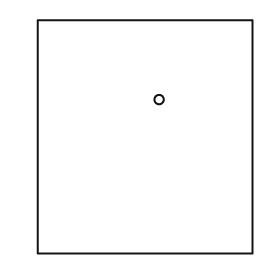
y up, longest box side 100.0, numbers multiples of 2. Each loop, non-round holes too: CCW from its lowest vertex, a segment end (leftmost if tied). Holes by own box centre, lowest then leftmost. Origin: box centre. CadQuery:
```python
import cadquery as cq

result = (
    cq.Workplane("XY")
    .moveTo(-46.0, -50.0)
    .lineTo(46.0, -50.0)
    .lineTo(46.0, 50.0)
    .lineTo(-46.0, 50.0)
    .close()
    .moveTo(6.0, 16.0)
    .circle(2.0)
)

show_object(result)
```